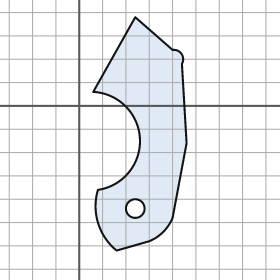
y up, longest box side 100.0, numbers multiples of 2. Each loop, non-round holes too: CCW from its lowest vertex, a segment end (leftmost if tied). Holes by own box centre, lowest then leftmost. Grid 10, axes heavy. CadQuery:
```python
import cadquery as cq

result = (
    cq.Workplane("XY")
    .moveTo(16.0, -62.0)
    .lineTo(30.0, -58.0)
    .threePointArc((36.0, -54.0), (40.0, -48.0))
    .lineTo(46.0, -16.0)
    .lineTo(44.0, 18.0)
    .threePointArc((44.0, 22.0), (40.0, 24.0))
    .lineTo(24.0, 38.0)
    .lineTo(6.0, 6.0)
    .threePointArc((26.0, -14.0), (8.0, -36.0))
    .threePointArc((8.0, -50.0), (16.0, -62.0))
    .close()
    .moveTo(24.0, -44.0)
    .circle(4.0)
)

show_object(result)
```